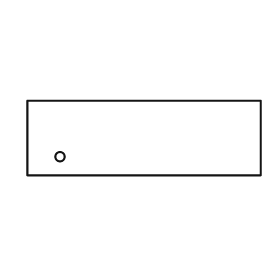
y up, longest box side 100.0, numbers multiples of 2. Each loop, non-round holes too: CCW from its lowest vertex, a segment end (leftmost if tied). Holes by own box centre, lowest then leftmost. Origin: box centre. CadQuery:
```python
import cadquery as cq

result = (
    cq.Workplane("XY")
    .moveTo(-50.0, -16.0)
    .lineTo(50.0, -16.0)
    .lineTo(50.0, 16.0)
    .lineTo(-50.0, 16.0)
    .close()
    .moveTo(-36.0, -8.0)
    .circle(2.0)
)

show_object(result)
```